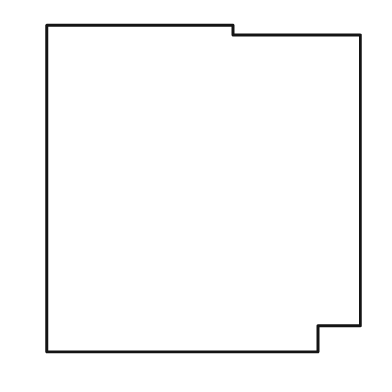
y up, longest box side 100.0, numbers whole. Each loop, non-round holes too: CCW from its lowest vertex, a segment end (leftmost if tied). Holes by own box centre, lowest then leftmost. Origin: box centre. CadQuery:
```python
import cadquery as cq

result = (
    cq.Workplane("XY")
    .moveTo(-48.0, -50.0)
    .lineTo(35.0, -50.0)
    .lineTo(35.0, -42.0)
    .lineTo(48.0, -42.0)
    .lineTo(48.0, 47.0)
    .lineTo(9.0, 47.0)
    .lineTo(9.0, 50.0)
    .lineTo(-48.0, 50.0)
    .close()
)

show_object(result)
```